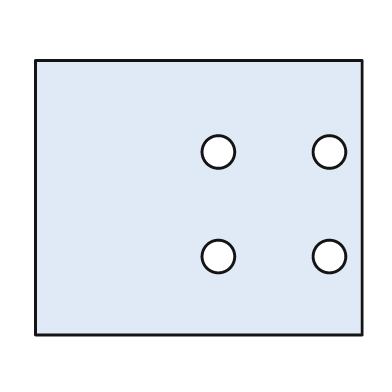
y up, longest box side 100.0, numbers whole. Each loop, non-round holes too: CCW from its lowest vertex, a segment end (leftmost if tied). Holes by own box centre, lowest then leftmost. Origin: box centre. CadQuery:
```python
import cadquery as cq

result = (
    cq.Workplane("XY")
    .moveTo(-50.0, -42.0)
    .lineTo(50.0, -42.0)
    .lineTo(50.0, 42.0)
    .lineTo(-50.0, 42.0)
    .close()
    .moveTo(6.0, -18.0)
    .circle(5.0)
    .moveTo(40.0, -18.0)
    .circle(5.0)
    .moveTo(6.0, 14.0)
    .circle(5.0)
    .moveTo(40.0, 14.0)
    .circle(5.0)
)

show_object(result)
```